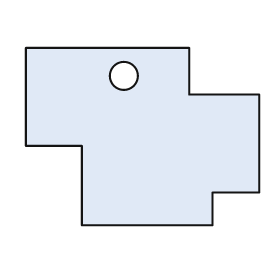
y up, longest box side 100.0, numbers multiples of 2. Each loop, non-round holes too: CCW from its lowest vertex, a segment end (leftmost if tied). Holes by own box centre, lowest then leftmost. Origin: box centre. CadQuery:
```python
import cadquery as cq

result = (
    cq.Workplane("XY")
    .moveTo(-26.0, -38.0)
    .lineTo(30.0, -38.0)
    .lineTo(30.0, -24.0)
    .lineTo(50.0, -24.0)
    .lineTo(50.0, 18.0)
    .lineTo(20.0, 18.0)
    .lineTo(20.0, 38.0)
    .lineTo(-50.0, 38.0)
    .lineTo(-50.0, -4.0)
    .lineTo(-26.0, -4.0)
    .close()
    .moveTo(-8.0, 26.0)
    .circle(6.0)
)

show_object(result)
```